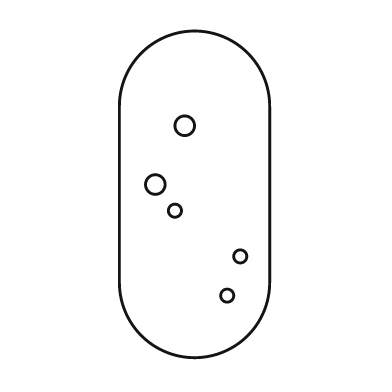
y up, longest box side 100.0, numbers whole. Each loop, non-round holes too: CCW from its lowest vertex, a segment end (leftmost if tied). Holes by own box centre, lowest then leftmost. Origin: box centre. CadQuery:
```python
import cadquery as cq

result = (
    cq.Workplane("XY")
    .moveTo(-23.0, -27.0)
    .threePointArc((0.0, -50.0), (23.0, -27.0))
    .lineTo(23.0, 27.0)
    .threePointArc((0.0, 50.0), (-23.0, 27.0))
    .close()
    .moveTo(10.0, -31.0)
    .circle(2.0)
    .moveTo(14.0, -19.0)
    .circle(2.0)
    .moveTo(-6.0, -5.0)
    .circle(2.0)
    .moveTo(-12.0, 3.0)
    .circle(3.0)
    .moveTo(-3.0, 21.0)
    .circle(3.0)
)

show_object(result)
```